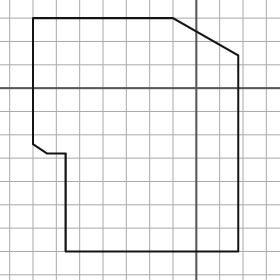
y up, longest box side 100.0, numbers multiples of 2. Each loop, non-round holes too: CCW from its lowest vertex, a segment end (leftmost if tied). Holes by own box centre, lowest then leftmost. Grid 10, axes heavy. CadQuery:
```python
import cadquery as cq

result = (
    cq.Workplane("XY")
    .moveTo(-56.0, -70.0)
    .lineTo(18.0, -70.0)
    .lineTo(18.0, 14.0)
    .lineTo(-10.0, 30.0)
    .lineTo(-70.0, 30.0)
    .lineTo(-70.0, -24.0)
    .lineTo(-64.0, -28.0)
    .lineTo(-56.0, -28.0)
    .close()
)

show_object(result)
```